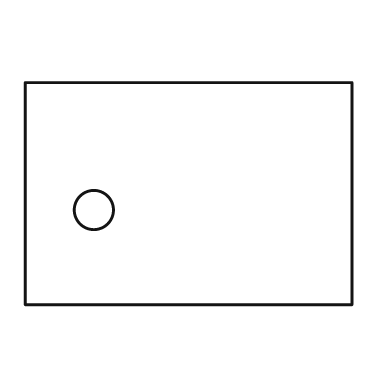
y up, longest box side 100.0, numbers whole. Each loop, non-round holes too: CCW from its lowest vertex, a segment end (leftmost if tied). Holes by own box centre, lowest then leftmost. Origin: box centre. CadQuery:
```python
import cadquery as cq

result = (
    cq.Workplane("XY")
    .moveTo(-50.0, -34.0)
    .lineTo(50.0, -34.0)
    .lineTo(50.0, 34.0)
    .lineTo(-50.0, 34.0)
    .close()
    .moveTo(-29.0, -5.0)
    .circle(6.0)
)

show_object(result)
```